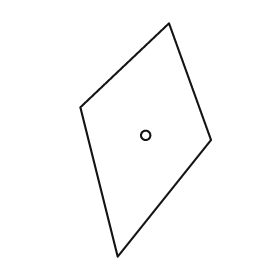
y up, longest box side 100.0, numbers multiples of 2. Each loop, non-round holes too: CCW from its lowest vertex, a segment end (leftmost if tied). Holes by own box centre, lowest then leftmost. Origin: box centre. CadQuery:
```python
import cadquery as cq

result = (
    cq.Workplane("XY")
    .moveTo(-12.0, -50.0)
    .lineTo(28.0, 0.0)
    .lineTo(10.0, 50.0)
    .lineTo(-28.0, 14.0)
    .close()
    .moveTo(0.0, 2.0)
    .circle(2.0)
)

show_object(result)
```